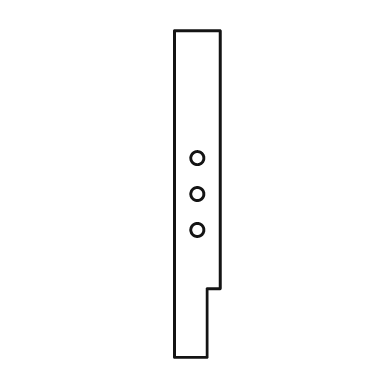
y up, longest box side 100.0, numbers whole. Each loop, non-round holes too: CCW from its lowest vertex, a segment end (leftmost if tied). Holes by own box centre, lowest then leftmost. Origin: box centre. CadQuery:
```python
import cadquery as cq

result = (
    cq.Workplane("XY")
    .moveTo(-7.0, -50.0)
    .lineTo(3.0, -50.0)
    .lineTo(3.0, -29.0)
    .lineTo(7.0, -29.0)
    .lineTo(7.0, 50.0)
    .lineTo(-7.0, 50.0)
    .close()
    .moveTo(0.0, -11.0)
    .circle(2.0)
    .moveTo(0.0, 0.0)
    .circle(2.0)
    .moveTo(0.0, 11.0)
    .circle(2.0)
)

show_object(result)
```